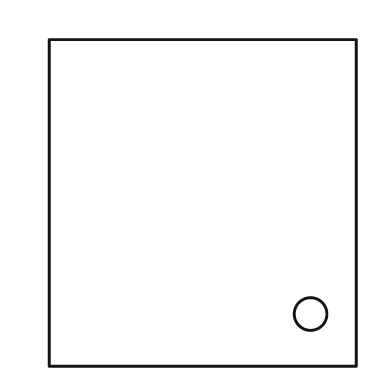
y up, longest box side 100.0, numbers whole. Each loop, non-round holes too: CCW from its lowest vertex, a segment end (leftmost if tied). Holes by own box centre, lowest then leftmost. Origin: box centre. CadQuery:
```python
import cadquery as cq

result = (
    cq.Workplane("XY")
    .moveTo(-47.0, -50.0)
    .lineTo(47.0, -50.0)
    .lineTo(47.0, 50.0)
    .lineTo(-47.0, 50.0)
    .close()
    .moveTo(33.0, -34.0)
    .circle(5.0)
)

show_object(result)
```